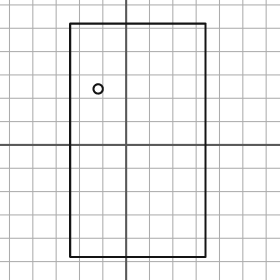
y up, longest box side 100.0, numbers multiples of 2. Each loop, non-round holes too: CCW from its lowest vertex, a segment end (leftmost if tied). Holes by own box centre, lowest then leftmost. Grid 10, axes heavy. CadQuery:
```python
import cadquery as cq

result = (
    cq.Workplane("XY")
    .moveTo(-24.0, -48.0)
    .lineTo(34.0, -48.0)
    .lineTo(34.0, 52.0)
    .lineTo(-24.0, 52.0)
    .close()
    .moveTo(-12.0, 24.0)
    .circle(2.0)
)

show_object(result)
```